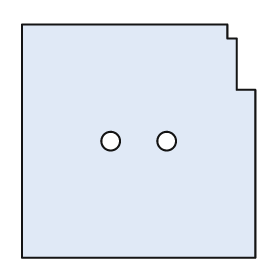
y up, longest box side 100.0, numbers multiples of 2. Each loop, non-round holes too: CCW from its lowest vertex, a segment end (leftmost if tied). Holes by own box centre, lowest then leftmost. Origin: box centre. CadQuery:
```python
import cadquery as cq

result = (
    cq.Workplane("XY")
    .moveTo(-50.0, -50.0)
    .lineTo(50.0, -50.0)
    .lineTo(50.0, 22.0)
    .lineTo(42.0, 22.0)
    .lineTo(42.0, 44.0)
    .lineTo(38.0, 44.0)
    .lineTo(38.0, 50.0)
    .lineTo(-50.0, 50.0)
    .close()
    .moveTo(-12.0, 0.0)
    .circle(4.0)
    .moveTo(12.0, 0.0)
    .circle(4.0)
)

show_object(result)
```